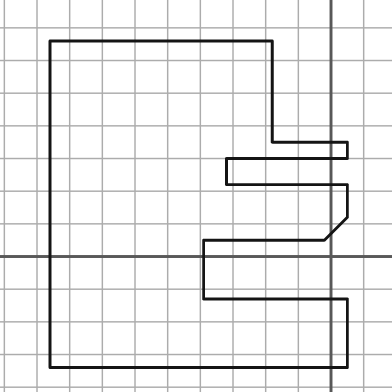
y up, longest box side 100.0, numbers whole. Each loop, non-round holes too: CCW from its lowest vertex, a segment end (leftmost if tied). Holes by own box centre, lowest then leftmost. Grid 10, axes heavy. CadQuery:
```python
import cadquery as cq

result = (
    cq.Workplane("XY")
    .moveTo(-86.0, -34.0)
    .lineTo(5.0, -34.0)
    .lineTo(5.0, -13.0)
    .lineTo(-39.0, -13.0)
    .lineTo(-39.0, 5.0)
    .lineTo(-2.0, 5.0)
    .lineTo(5.0, 12.0)
    .lineTo(5.0, 22.0)
    .lineTo(-32.0, 22.0)
    .lineTo(-32.0, 30.0)
    .lineTo(5.0, 30.0)
    .lineTo(5.0, 35.0)
    .lineTo(-18.0, 35.0)
    .lineTo(-18.0, 66.0)
    .lineTo(-86.0, 66.0)
    .close()
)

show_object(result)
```